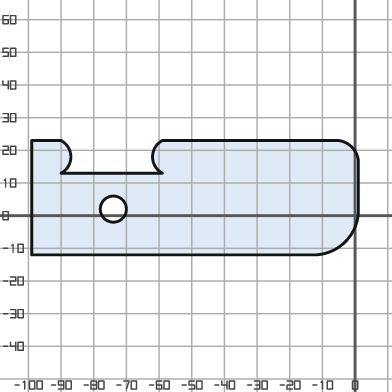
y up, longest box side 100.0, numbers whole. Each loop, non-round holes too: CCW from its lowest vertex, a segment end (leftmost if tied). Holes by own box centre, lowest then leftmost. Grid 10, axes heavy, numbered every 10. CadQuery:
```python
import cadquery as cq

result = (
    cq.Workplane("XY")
    .moveTo(-99.0, -12.0)
    .lineTo(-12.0, -12.0)
    .threePointArc((-3.0, -8.0), (1.0, 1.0))
    .lineTo(1.0, 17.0)
    .threePointArc((-1.0, 21.0), (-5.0, 23.0))
    .lineTo(-59.0, 23.0)
    .threePointArc((-62.0, 18.0), (-59.0, 13.0))
    .lineTo(-90.0, 13.0)
    .threePointArc((-87.0, 18.0), (-90.0, 23.0))
    .lineTo(-99.0, 23.0)
    .close()
    .moveTo(-74.0, 2.0)
    .circle(4.0)
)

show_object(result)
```